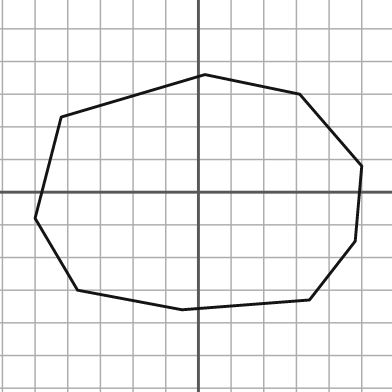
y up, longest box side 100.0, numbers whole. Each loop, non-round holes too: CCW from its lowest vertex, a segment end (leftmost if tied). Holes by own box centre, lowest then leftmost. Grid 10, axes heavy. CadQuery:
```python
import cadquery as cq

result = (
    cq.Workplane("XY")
    .moveTo(-5.0, -36.0)
    .lineTo(34.0, -33.0)
    .lineTo(48.0, -15.0)
    .lineTo(50.0, 8.0)
    .lineTo(31.0, 30.0)
    .lineTo(2.0, 36.0)
    .lineTo(-42.0, 23.0)
    .lineTo(-50.0, -8.0)
    .lineTo(-37.0, -30.0)
    .close()
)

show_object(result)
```